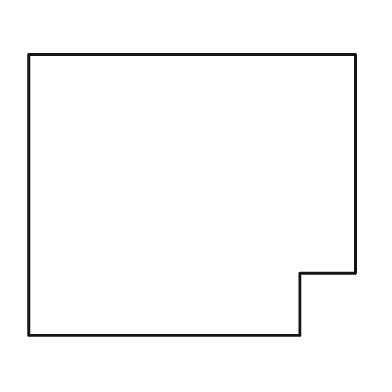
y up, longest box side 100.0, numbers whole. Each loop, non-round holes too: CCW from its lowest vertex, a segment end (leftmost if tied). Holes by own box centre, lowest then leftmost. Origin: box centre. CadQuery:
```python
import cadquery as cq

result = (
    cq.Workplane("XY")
    .moveTo(-50.0, -43.0)
    .lineTo(33.0, -43.0)
    .lineTo(33.0, -24.0)
    .lineTo(50.0, -24.0)
    .lineTo(50.0, 43.0)
    .lineTo(-50.0, 43.0)
    .close()
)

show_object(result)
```